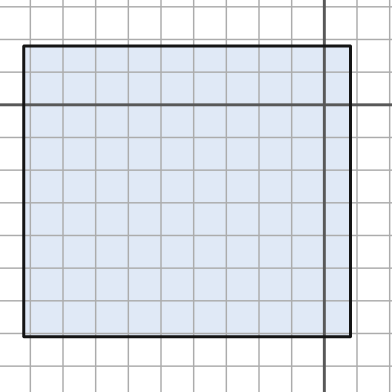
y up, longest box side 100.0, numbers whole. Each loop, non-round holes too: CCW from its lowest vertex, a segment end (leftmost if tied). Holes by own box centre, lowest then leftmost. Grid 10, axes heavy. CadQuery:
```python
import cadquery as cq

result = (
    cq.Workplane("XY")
    .moveTo(-92.0, -71.0)
    .lineTo(8.0, -71.0)
    .lineTo(8.0, 18.0)
    .lineTo(-92.0, 18.0)
    .close()
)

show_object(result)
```